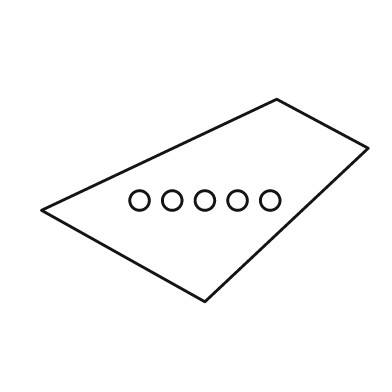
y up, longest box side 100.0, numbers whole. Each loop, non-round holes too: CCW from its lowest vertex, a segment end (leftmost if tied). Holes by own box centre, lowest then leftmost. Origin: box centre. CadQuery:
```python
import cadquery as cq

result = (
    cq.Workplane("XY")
    .moveTo(0.0, -31.0)
    .lineTo(50.0, 16.0)
    .lineTo(22.0, 31.0)
    .lineTo(-50.0, -3.0)
    .close()
    .moveTo(-20.0, 0.0)
    .circle(3.0)
    .moveTo(-10.0, 0.0)
    .circle(3.0)
    .moveTo(0.0, 0.0)
    .circle(3.0)
    .moveTo(10.0, 0.0)
    .circle(3.0)
    .moveTo(20.0, 0.0)
    .circle(3.0)
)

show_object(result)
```